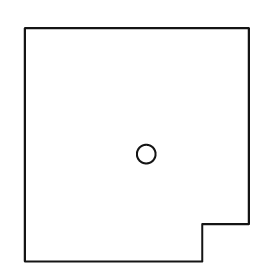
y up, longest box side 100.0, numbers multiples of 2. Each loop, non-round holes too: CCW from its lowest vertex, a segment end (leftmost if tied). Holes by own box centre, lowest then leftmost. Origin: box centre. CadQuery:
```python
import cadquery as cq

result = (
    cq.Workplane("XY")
    .moveTo(-48.0, -50.0)
    .lineTo(28.0, -50.0)
    .lineTo(28.0, -34.0)
    .lineTo(48.0, -34.0)
    .lineTo(48.0, 50.0)
    .lineTo(-48.0, 50.0)
    .close()
    .moveTo(4.0, -4.0)
    .circle(4.0)
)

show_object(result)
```